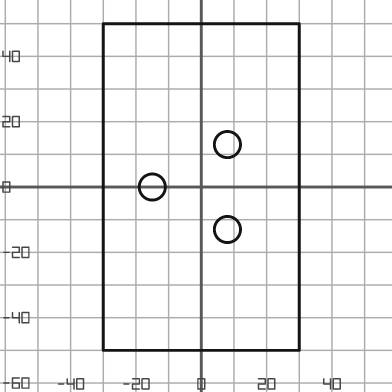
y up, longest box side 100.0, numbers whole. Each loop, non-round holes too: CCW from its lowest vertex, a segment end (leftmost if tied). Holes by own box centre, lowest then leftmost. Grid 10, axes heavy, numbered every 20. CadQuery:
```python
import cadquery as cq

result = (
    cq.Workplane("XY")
    .moveTo(-30.0, -50.0)
    .lineTo(30.0, -50.0)
    .lineTo(30.0, 50.0)
    .lineTo(-30.0, 50.0)
    .close()
    .moveTo(8.0, -13.0)
    .circle(4.0)
    .moveTo(-15.0, 0.0)
    .circle(4.0)
    .moveTo(8.0, 13.0)
    .circle(4.0)
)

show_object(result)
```